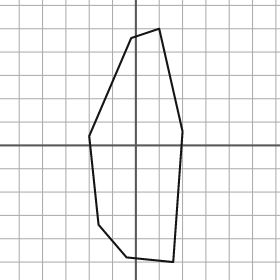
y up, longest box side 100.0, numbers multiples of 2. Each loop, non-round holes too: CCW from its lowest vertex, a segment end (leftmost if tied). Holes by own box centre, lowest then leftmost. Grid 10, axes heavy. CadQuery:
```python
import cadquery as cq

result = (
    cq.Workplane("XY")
    .moveTo(16.0, -50.0)
    .lineTo(20.0, 6.0)
    .lineTo(10.0, 50.0)
    .lineTo(-2.0, 46.0)
    .lineTo(-20.0, 4.0)
    .lineTo(-16.0, -34.0)
    .lineTo(-4.0, -48.0)
    .close()
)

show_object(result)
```